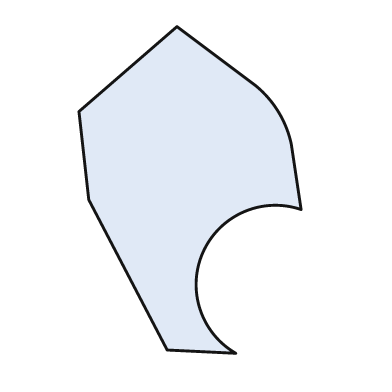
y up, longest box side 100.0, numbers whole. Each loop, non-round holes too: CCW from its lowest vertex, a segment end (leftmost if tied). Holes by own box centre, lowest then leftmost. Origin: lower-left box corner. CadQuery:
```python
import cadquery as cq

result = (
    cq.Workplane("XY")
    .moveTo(48.0, 0.0)
    .threePointArc((38.0, 31.0), (68.0, 44.0))
    .lineTo(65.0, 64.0)
    .threePointArc((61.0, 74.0), (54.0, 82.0))
    .lineTo(30.0, 100.0)
    .lineTo(0.0, 74.0)
    .lineTo(3.0, 47.0)
    .lineTo(27.0, 1.0)
    .close()
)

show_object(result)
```